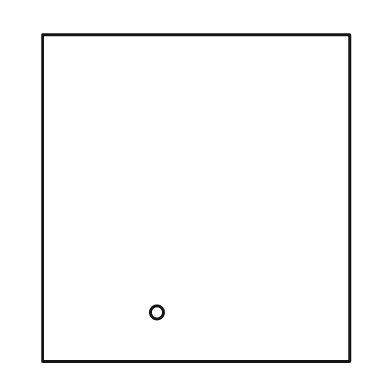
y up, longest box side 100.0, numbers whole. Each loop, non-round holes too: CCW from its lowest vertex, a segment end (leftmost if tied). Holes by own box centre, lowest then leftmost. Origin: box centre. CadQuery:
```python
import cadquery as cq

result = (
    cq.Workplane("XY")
    .moveTo(-47.0, -50.0)
    .lineTo(47.0, -50.0)
    .lineTo(47.0, 50.0)
    .lineTo(-47.0, 50.0)
    .close()
    .moveTo(-12.0, -35.0)
    .circle(2.0)
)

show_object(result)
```